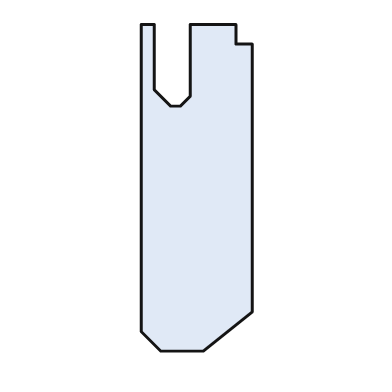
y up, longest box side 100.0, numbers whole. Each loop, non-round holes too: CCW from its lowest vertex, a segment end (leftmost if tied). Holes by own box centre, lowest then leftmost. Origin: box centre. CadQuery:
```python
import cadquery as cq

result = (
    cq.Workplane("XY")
    .moveTo(-11.0, -50.0)
    .lineTo(2.0, -50.0)
    .lineTo(17.0, -38.0)
    .lineTo(17.0, 44.0)
    .lineTo(12.0, 44.0)
    .lineTo(12.0, 50.0)
    .lineTo(-2.0, 50.0)
    .lineTo(-2.0, 28.0)
    .lineTo(-5.0, 25.0)
    .lineTo(-8.0, 25.0)
    .lineTo(-13.0, 30.0)
    .lineTo(-13.0, 50.0)
    .lineTo(-17.0, 50.0)
    .lineTo(-17.0, -44.0)
    .close()
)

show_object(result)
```